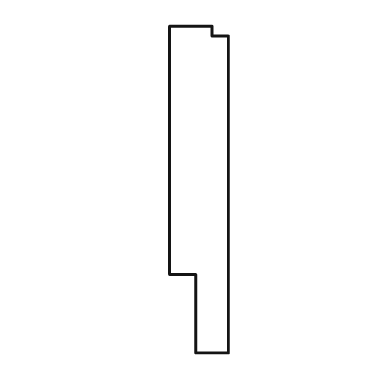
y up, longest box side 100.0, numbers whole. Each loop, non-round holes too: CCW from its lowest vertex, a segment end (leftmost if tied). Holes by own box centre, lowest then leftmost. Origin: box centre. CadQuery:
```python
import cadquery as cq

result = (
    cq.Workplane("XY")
    .moveTo(-1.0, -50.0)
    .lineTo(9.0, -50.0)
    .lineTo(9.0, 47.0)
    .lineTo(4.0, 47.0)
    .lineTo(4.0, 50.0)
    .lineTo(-9.0, 50.0)
    .lineTo(-9.0, -26.0)
    .lineTo(-1.0, -26.0)
    .close()
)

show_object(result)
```